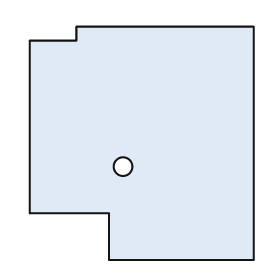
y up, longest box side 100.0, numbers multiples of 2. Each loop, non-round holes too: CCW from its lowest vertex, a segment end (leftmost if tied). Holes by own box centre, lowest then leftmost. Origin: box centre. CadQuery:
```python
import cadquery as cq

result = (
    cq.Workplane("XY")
    .moveTo(-14.0, -50.0)
    .lineTo(48.0, -50.0)
    .lineTo(48.0, 50.0)
    .lineTo(-28.0, 50.0)
    .lineTo(-28.0, 44.0)
    .lineTo(-48.0, 44.0)
    .lineTo(-48.0, -30.0)
    .lineTo(-14.0, -30.0)
    .close()
    .moveTo(-8.0, -10.0)
    .circle(4.0)
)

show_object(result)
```